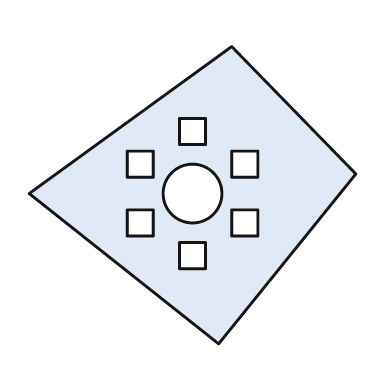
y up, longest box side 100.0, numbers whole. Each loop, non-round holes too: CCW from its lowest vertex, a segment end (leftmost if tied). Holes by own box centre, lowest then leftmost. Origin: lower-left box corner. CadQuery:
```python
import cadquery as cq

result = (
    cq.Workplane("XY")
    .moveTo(58.0, 0.0)
    .lineTo(100.0, 52.0)
    .lineTo(62.0, 91.0)
    .lineTo(0.0, 46.0)
    .close()
    .moveTo(46.0, 23.0)
    .lineTo(54.0, 23.0)
    .lineTo(54.0, 31.0)
    .lineTo(46.0, 31.0)
    .close()
    .moveTo(30.0, 33.0)
    .lineTo(38.0, 33.0)
    .lineTo(38.0, 41.0)
    .lineTo(30.0, 41.0)
    .close()
    .moveTo(62.0, 33.0)
    .lineTo(70.0, 33.0)
    .lineTo(70.0, 41.0)
    .lineTo(62.0, 41.0)
    .close()
    .moveTo(50.0, 46.0)
    .circle(9.0)
    .moveTo(30.0, 51.0)
    .lineTo(38.0, 51.0)
    .lineTo(38.0, 59.0)
    .lineTo(30.0, 59.0)
    .close()
    .moveTo(62.0, 51.0)
    .lineTo(70.0, 51.0)
    .lineTo(70.0, 59.0)
    .lineTo(62.0, 59.0)
    .close()
    .moveTo(46.0, 61.0)
    .lineTo(54.0, 61.0)
    .lineTo(54.0, 69.0)
    .lineTo(46.0, 69.0)
    .close()
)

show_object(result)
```